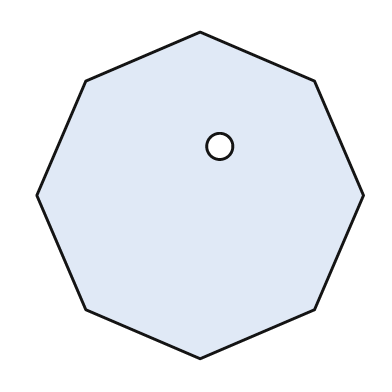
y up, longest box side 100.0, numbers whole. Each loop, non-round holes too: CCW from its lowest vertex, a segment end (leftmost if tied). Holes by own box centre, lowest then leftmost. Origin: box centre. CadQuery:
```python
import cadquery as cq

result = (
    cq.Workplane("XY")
    .moveTo(0.0, -50.0)
    .lineTo(35.0, -35.0)
    .lineTo(50.0, 0.0)
    .lineTo(35.0, 35.0)
    .lineTo(0.0, 50.0)
    .lineTo(-35.0, 35.0)
    .lineTo(-50.0, 0.0)
    .lineTo(-35.0, -35.0)
    .close()
    .moveTo(6.0, 15.0)
    .circle(4.0)
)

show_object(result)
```